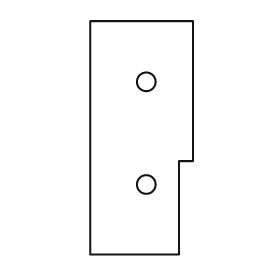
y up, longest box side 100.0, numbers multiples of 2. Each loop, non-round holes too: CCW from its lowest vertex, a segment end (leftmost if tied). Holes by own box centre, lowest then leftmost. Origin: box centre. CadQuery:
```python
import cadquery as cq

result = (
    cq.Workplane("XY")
    .moveTo(-22.0, -50.0)
    .lineTo(16.0, -50.0)
    .lineTo(16.0, -10.0)
    .lineTo(22.0, -10.0)
    .lineTo(22.0, 50.0)
    .lineTo(-22.0, 50.0)
    .close()
    .moveTo(2.0, -20.0)
    .circle(4.0)
    .moveTo(2.0, 24.0)
    .circle(4.0)
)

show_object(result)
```